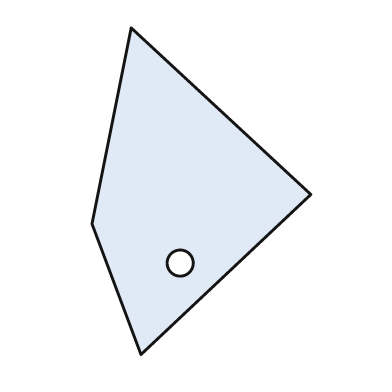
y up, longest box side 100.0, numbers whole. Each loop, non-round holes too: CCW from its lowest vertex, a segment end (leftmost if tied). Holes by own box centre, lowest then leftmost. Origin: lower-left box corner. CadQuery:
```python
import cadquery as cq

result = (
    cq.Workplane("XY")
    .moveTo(15.0, 0.0)
    .lineTo(67.0, 49.0)
    .lineTo(12.0, 100.0)
    .lineTo(0.0, 40.0)
    .close()
    .moveTo(27.0, 28.0)
    .circle(4.0)
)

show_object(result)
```